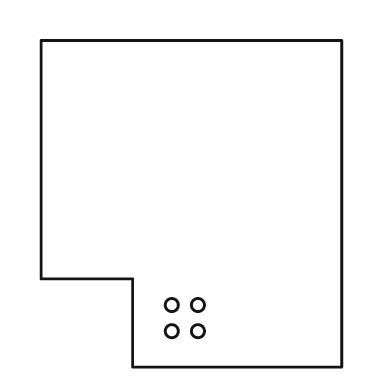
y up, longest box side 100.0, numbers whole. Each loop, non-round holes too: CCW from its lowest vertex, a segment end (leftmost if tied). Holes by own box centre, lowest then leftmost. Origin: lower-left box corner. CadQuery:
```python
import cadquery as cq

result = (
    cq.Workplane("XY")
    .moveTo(28.0, 0.0)
    .lineTo(92.0, 0.0)
    .lineTo(92.0, 100.0)
    .lineTo(0.0, 100.0)
    .lineTo(0.0, 27.0)
    .lineTo(28.0, 27.0)
    .close()
    .moveTo(40.0, 11.0)
    .circle(2.0)
    .moveTo(48.0, 11.0)
    .circle(2.0)
    .moveTo(40.0, 19.0)
    .circle(2.0)
    .moveTo(48.0, 19.0)
    .circle(2.0)
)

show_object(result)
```